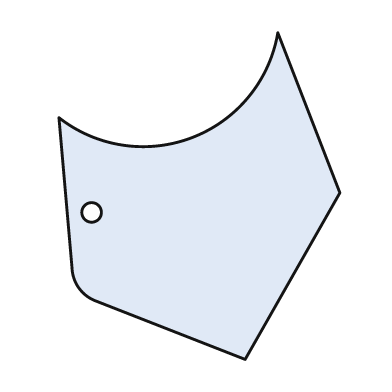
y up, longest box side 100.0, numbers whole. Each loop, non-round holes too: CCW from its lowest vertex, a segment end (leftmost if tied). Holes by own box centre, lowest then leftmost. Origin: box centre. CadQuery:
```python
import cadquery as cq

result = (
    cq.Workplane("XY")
    .moveTo(14.0, -50.0)
    .lineTo(43.0, 1.0)
    .lineTo(24.0, 50.0)
    .threePointArc((-2.0, 18.0), (-43.0, 24.0))
    .lineTo(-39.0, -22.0)
    .threePointArc((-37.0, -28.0), (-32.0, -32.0))
    .close()
    .moveTo(-33.0, -5.0)
    .circle(3.0)
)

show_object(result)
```